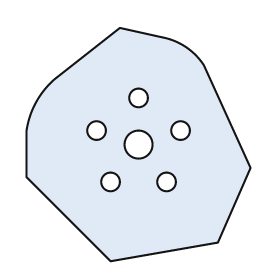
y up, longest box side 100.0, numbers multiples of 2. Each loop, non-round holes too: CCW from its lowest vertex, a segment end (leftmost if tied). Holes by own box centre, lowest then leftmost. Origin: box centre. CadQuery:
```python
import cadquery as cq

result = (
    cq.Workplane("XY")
    .moveTo(-12.0, -50.0)
    .lineTo(34.0, -42.0)
    .lineTo(48.0, -10.0)
    .lineTo(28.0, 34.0)
    .threePointArc((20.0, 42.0), (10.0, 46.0))
    .lineTo(-8.0, 50.0)
    .lineTo(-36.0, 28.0)
    .threePointArc((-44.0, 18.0), (-48.0, 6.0))
    .lineTo(-48.0, -14.0)
    .close()
    .moveTo(-12.0, -16.0)
    .circle(4.0)
    .moveTo(12.0, -16.0)
    .circle(4.0)
    .moveTo(0.0, 0.0)
    .circle(6.0)
    .moveTo(-18.0, 6.0)
    .circle(4.0)
    .moveTo(18.0, 6.0)
    .circle(4.0)
    .moveTo(0.0, 20.0)
    .circle(4.0)
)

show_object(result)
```